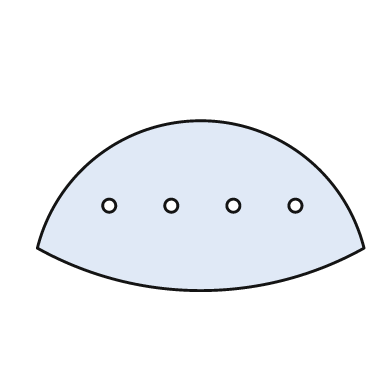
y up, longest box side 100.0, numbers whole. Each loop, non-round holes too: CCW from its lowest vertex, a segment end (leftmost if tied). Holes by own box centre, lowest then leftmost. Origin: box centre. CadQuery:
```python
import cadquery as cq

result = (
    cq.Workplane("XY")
    .moveTo(-50.0, -13.0)
    .threePointArc((0.0, -26.0), (50.0, -13.0))
    .threePointArc((0.0, 26.0), (-50.0, -13.0))
    .close()
    .moveTo(-28.0, 0.0)
    .circle(2.0)
    .moveTo(-9.0, 0.0)
    .circle(2.0)
    .moveTo(10.0, 0.0)
    .circle(2.0)
    .moveTo(29.0, 0.0)
    .circle(2.0)
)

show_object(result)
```